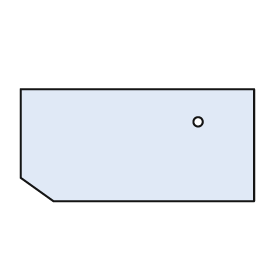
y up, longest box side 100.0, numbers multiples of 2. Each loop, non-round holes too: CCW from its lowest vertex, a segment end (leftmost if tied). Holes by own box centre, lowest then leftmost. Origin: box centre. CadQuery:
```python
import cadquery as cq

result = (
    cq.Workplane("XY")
    .moveTo(-36.0, -24.0)
    .lineTo(50.0, -24.0)
    .lineTo(50.0, 24.0)
    .lineTo(-50.0, 24.0)
    .lineTo(-50.0, -14.0)
    .close()
    .moveTo(26.0, 10.0)
    .circle(2.0)
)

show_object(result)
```